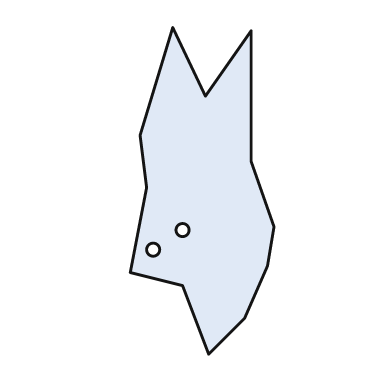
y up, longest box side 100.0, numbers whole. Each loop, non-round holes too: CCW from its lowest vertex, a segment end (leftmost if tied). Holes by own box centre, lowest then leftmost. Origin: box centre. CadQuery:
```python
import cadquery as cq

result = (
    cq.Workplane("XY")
    .moveTo(2.0, -50.0)
    .lineTo(13.0, -39.0)
    .lineTo(20.0, -23.0)
    .lineTo(22.0, -11.0)
    .lineTo(15.0, 9.0)
    .lineTo(15.0, 49.0)
    .lineTo(1.0, 29.0)
    .lineTo(-9.0, 50.0)
    .lineTo(-19.0, 17.0)
    .lineTo(-17.0, 1.0)
    .lineTo(-22.0, -25.0)
    .lineTo(-6.0, -29.0)
    .close()
    .moveTo(-15.0, -18.0)
    .circle(2.0)
    .moveTo(-6.0, -12.0)
    .circle(2.0)
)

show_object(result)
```